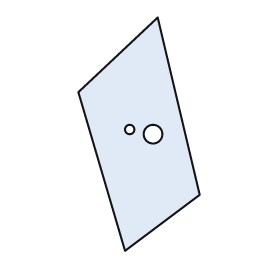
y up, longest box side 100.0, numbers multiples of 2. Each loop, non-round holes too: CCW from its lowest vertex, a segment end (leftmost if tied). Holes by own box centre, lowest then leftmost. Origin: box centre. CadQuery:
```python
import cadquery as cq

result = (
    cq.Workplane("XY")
    .moveTo(-6.0, -50.0)
    .lineTo(26.0, -26.0)
    .lineTo(8.0, 50.0)
    .lineTo(-26.0, 18.0)
    .close()
    .moveTo(6.0, 0.0)
    .circle(4.0)
    .moveTo(-4.0, 2.0)
    .circle(2.0)
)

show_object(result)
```